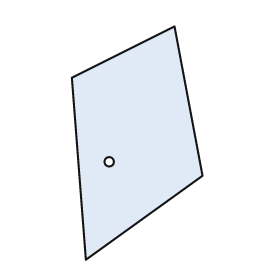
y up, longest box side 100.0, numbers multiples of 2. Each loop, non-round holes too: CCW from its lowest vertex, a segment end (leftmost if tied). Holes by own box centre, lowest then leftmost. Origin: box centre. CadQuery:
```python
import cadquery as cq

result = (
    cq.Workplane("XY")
    .moveTo(-22.0, -50.0)
    .lineTo(28.0, -14.0)
    .lineTo(16.0, 50.0)
    .lineTo(-28.0, 28.0)
    .close()
    .moveTo(-12.0, -8.0)
    .circle(2.0)
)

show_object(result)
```